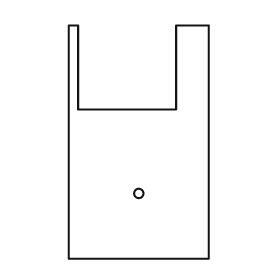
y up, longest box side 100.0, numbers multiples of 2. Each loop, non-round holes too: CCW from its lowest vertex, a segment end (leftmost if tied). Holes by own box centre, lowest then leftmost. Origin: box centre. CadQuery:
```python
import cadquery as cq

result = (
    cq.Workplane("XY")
    .moveTo(-30.0, -50.0)
    .lineTo(30.0, -50.0)
    .lineTo(30.0, 50.0)
    .lineTo(16.0, 50.0)
    .lineTo(16.0, 14.0)
    .lineTo(-26.0, 14.0)
    .lineTo(-26.0, 50.0)
    .lineTo(-30.0, 50.0)
    .close()
    .moveTo(0.0, -22.0)
    .circle(2.0)
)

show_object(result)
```